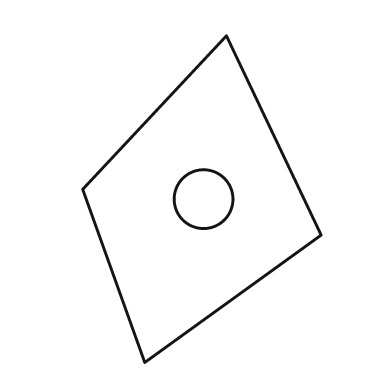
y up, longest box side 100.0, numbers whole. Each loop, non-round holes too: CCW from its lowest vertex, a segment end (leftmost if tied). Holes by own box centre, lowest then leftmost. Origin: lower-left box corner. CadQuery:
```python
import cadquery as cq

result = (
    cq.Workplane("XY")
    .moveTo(19.0, 0.0)
    .lineTo(73.0, 39.0)
    .lineTo(44.0, 100.0)
    .lineTo(0.0, 53.0)
    .close()
    .moveTo(37.0, 50.0)
    .circle(9.0)
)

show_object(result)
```